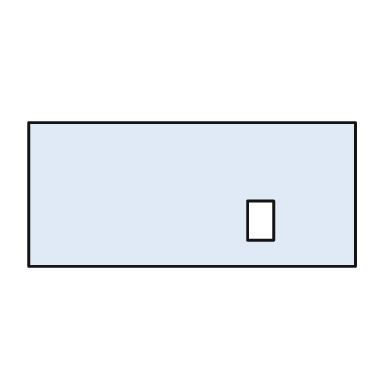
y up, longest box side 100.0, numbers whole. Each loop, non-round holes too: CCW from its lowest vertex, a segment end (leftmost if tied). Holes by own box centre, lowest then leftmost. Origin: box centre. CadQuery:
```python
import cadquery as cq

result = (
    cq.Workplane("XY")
    .moveTo(-50.0, -22.0)
    .lineTo(50.0, -22.0)
    .lineTo(50.0, 22.0)
    .lineTo(-50.0, 22.0)
    .close()
    .moveTo(17.0, -14.0)
    .lineTo(25.0, -14.0)
    .lineTo(25.0, -2.0)
    .lineTo(17.0, -2.0)
    .close()
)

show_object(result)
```